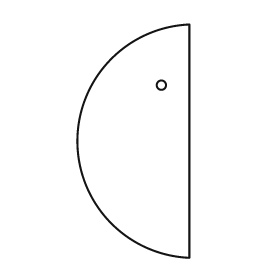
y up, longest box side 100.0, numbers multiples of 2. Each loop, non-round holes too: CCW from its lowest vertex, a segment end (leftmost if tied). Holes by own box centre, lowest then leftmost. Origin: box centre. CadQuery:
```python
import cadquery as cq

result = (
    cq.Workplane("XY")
    .moveTo(24.0, -50.0)
    .lineTo(24.0, 50.0)
    .threePointArc((-24.0, 0.0), (24.0, -50.0))
    .close()
    .moveTo(12.0, 24.0)
    .circle(2.0)
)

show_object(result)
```